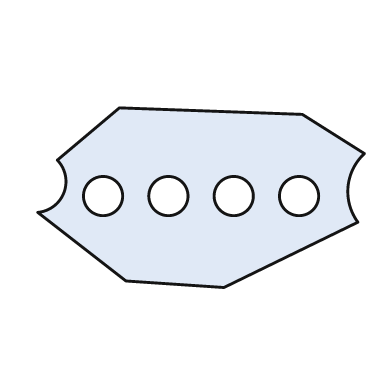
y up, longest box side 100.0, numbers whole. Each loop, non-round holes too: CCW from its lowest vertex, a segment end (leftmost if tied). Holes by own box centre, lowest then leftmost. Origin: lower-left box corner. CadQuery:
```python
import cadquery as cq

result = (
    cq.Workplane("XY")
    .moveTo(57.0, 0.0)
    .lineTo(98.0, 20.0)
    .threePointArc((95.0, 31.0), (100.0, 41.0))
    .lineTo(81.0, 53.0)
    .lineTo(25.0, 55.0)
    .lineTo(6.0, 39.0)
    .threePointArc((8.0, 29.0), (0.0, 23.0))
    .lineTo(27.0, 2.0)
    .close()
    .moveTo(20.0, 28.0)
    .circle(6.0)
    .moveTo(40.0, 28.0)
    .circle(6.0)
    .moveTo(60.0, 28.0)
    .circle(6.0)
    .moveTo(80.0, 28.0)
    .circle(6.0)
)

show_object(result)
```